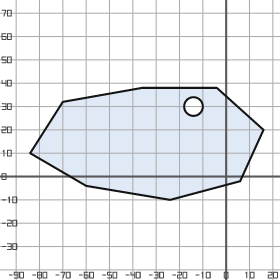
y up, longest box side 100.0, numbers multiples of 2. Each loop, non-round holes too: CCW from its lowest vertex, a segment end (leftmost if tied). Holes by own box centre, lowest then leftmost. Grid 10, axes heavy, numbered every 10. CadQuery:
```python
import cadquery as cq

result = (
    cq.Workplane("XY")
    .moveTo(-24.0, -10.0)
    .lineTo(6.0, -2.0)
    .lineTo(16.0, 20.0)
    .lineTo(-4.0, 38.0)
    .lineTo(-36.0, 38.0)
    .lineTo(-70.0, 32.0)
    .lineTo(-84.0, 10.0)
    .lineTo(-60.0, -4.0)
    .close()
    .moveTo(-14.0, 30.0)
    .circle(4.0)
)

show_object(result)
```